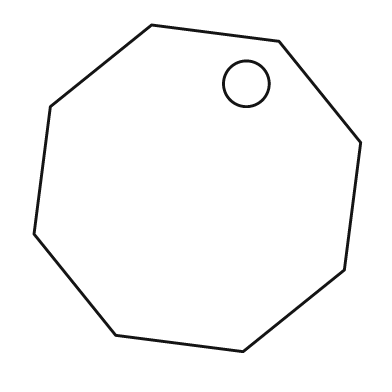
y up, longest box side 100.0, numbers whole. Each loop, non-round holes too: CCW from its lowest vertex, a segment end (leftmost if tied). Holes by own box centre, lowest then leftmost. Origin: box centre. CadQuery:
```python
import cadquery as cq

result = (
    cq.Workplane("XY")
    .moveTo(14.0, -50.0)
    .lineTo(45.0, -25.0)
    .lineTo(50.0, 14.0)
    .lineTo(25.0, 45.0)
    .lineTo(-14.0, 50.0)
    .lineTo(-45.0, 25.0)
    .lineTo(-50.0, -14.0)
    .lineTo(-25.0, -45.0)
    .close()
    .moveTo(15.0, 32.0)
    .circle(7.0)
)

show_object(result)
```